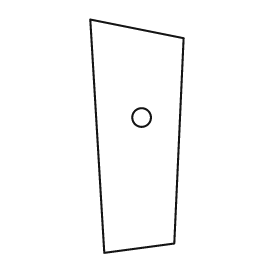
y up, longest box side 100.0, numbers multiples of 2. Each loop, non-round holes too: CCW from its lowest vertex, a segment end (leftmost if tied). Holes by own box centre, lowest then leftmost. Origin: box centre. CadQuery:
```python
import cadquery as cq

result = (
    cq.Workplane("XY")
    .moveTo(-14.0, -50.0)
    .lineTo(16.0, -46.0)
    .lineTo(20.0, 42.0)
    .lineTo(-20.0, 50.0)
    .close()
    .moveTo(2.0, 8.0)
    .circle(4.0)
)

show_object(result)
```